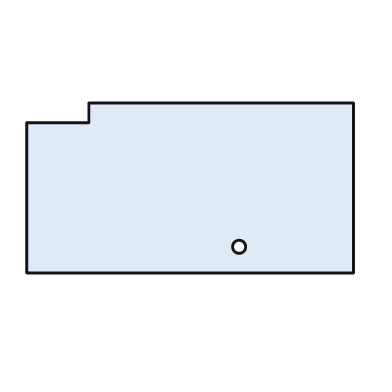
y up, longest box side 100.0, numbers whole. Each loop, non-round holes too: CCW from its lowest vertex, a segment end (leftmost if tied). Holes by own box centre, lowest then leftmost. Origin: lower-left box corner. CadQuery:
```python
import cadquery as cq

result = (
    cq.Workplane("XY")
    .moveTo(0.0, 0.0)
    .lineTo(100.0, 0.0)
    .lineTo(100.0, 52.0)
    .lineTo(19.0, 52.0)
    .lineTo(19.0, 46.0)
    .lineTo(0.0, 46.0)
    .close()
    .moveTo(65.0, 8.0)
    .circle(2.0)
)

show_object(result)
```